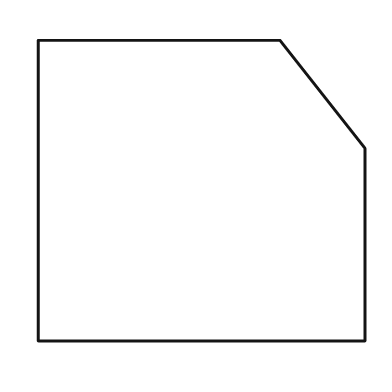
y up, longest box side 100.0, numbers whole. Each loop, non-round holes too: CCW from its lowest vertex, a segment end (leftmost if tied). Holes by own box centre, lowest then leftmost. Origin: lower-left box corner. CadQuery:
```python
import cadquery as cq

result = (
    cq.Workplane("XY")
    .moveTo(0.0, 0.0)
    .lineTo(100.0, 0.0)
    .lineTo(100.0, 59.0)
    .lineTo(74.0, 92.0)
    .lineTo(0.0, 92.0)
    .close()
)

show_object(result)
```